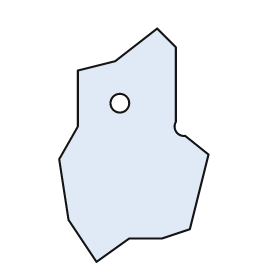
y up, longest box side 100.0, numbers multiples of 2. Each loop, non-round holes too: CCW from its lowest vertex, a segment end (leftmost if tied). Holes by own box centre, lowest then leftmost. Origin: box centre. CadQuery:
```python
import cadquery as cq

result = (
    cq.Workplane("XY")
    .moveTo(-16.0, -50.0)
    .lineTo(-2.0, -40.0)
    .lineTo(12.0, -40.0)
    .lineTo(24.0, -36.0)
    .lineTo(32.0, -4.0)
    .lineTo(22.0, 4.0)
    .threePointArc((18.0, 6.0), (18.0, 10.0))
    .lineTo(18.0, 42.0)
    .lineTo(10.0, 50.0)
    .lineTo(-8.0, 36.0)
    .lineTo(-24.0, 32.0)
    .lineTo(-24.0, 8.0)
    .lineTo(-32.0, -6.0)
    .lineTo(-28.0, -32.0)
    .close()
    .moveTo(-6.0, 18.0)
    .circle(4.0)
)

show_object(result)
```